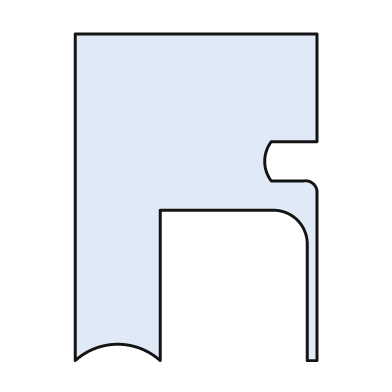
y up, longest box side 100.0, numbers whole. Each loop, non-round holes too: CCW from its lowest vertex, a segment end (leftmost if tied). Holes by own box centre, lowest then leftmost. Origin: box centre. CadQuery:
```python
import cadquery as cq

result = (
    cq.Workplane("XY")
    .moveTo(-37.0, -50.0)
    .threePointArc((-24.0, -45.0), (-11.0, -50.0))
    .lineTo(-11.0, -4.0)
    .lineTo(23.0, -4.0)
    .threePointArc((31.0, -7.0), (34.0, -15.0))
    .lineTo(34.0, -50.0)
    .lineTo(37.0, -50.0)
    .lineTo(37.0, 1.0)
    .threePointArc((36.0, 4.0), (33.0, 5.0))
    .lineTo(23.0, 5.0)
    .threePointArc((21.0, 11.0), (23.0, 17.0))
    .lineTo(37.0, 17.0)
    .lineTo(37.0, 50.0)
    .lineTo(-37.0, 50.0)
    .close()
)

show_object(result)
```